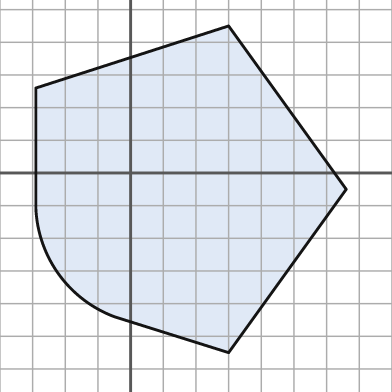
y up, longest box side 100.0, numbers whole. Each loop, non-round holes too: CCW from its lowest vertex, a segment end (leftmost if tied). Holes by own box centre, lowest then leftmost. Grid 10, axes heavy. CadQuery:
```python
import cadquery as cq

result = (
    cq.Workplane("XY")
    .moveTo(30.0, -55.0)
    .lineTo(66.0, -5.0)
    .lineTo(30.0, 45.0)
    .lineTo(-29.0, 26.0)
    .lineTo(-29.0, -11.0)
    .threePointArc((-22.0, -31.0), (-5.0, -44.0))
    .close()
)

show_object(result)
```